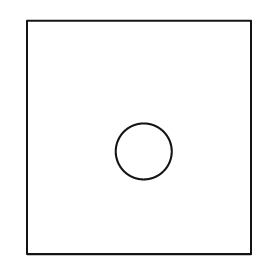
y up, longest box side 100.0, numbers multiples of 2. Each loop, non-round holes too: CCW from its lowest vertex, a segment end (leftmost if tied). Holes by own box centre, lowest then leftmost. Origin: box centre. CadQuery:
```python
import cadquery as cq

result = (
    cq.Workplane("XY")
    .moveTo(-48.0, -50.0)
    .lineTo(48.0, -50.0)
    .lineTo(48.0, 50.0)
    .lineTo(-48.0, 50.0)
    .close()
    .moveTo(2.0, -6.0)
    .circle(12.0)
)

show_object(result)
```